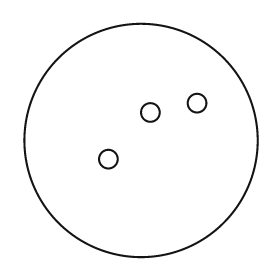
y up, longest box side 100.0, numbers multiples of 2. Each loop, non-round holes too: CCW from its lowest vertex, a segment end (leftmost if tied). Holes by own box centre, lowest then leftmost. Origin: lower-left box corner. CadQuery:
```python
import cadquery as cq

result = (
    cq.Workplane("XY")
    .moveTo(50.0, 50.0)
    .circle(50.0)
    .moveTo(36.0, 42.0)
    .circle(4.0)
    .moveTo(54.0, 62.0)
    .circle(4.0)
    .moveTo(74.0, 66.0)
    .circle(4.0)
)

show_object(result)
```